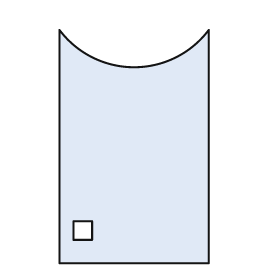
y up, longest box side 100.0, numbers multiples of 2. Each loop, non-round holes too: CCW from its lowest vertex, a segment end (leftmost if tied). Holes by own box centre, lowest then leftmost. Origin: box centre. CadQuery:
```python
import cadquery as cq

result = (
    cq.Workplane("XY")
    .moveTo(-32.0, -50.0)
    .lineTo(32.0, -50.0)
    .lineTo(32.0, 50.0)
    .threePointArc((0.0, 34.0), (-32.0, 50.0))
    .close()
    .moveTo(-26.0, -40.0)
    .lineTo(-18.0, -40.0)
    .lineTo(-18.0, -32.0)
    .lineTo(-26.0, -32.0)
    .close()
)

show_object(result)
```